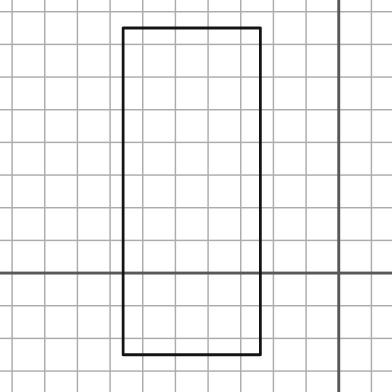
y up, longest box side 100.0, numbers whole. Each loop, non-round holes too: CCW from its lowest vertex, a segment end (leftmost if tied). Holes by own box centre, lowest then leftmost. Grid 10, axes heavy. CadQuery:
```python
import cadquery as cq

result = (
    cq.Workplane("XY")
    .moveTo(-66.0, -25.0)
    .lineTo(-24.0, -25.0)
    .lineTo(-24.0, 75.0)
    .lineTo(-66.0, 75.0)
    .close()
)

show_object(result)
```